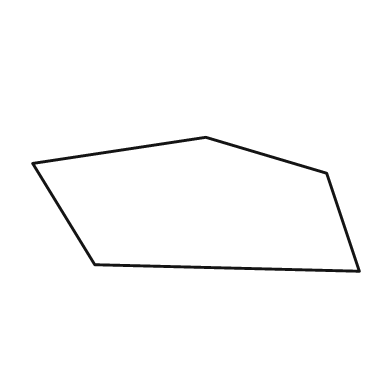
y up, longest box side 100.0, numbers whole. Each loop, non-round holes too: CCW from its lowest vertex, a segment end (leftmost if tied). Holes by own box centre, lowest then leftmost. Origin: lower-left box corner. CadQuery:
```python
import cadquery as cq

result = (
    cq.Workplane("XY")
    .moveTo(100.0, 0.0)
    .lineTo(90.0, 30.0)
    .lineTo(53.0, 41.0)
    .lineTo(0.0, 33.0)
    .lineTo(19.0, 2.0)
    .close()
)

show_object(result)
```